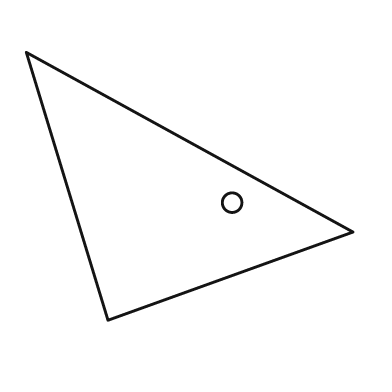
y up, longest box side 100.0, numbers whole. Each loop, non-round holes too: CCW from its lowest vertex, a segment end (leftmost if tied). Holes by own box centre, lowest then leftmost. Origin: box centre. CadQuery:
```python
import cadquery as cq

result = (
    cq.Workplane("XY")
    .moveTo(-25.0, -41.0)
    .lineTo(50.0, -14.0)
    .lineTo(-50.0, 41.0)
    .close()
    .moveTo(13.0, -5.0)
    .circle(3.0)
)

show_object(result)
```